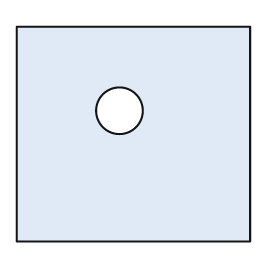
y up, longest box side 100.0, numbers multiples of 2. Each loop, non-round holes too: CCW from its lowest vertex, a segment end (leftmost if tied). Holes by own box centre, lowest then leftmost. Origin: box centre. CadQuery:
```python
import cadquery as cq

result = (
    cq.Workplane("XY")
    .moveTo(-50.0, -46.0)
    .lineTo(50.0, -46.0)
    .lineTo(50.0, 46.0)
    .lineTo(-50.0, 46.0)
    .close()
    .moveTo(-6.0, 10.0)
    .circle(10.0)
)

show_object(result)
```